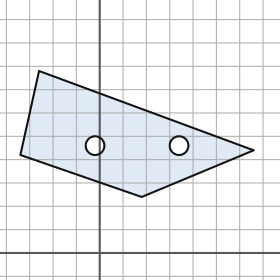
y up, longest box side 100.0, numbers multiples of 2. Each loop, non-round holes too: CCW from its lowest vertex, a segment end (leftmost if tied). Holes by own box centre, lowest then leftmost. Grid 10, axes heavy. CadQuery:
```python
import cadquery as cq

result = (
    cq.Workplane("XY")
    .moveTo(18.0, 24.0)
    .lineTo(66.0, 44.0)
    .lineTo(-26.0, 78.0)
    .lineTo(-34.0, 42.0)
    .close()
    .moveTo(-2.0, 46.0)
    .circle(4.0)
    .moveTo(34.0, 46.0)
    .circle(4.0)
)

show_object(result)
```